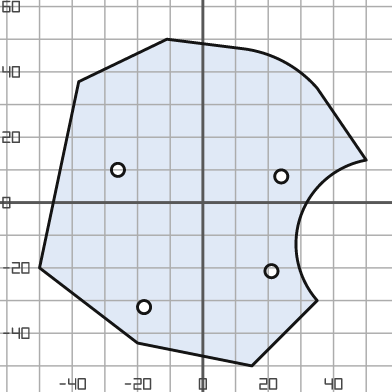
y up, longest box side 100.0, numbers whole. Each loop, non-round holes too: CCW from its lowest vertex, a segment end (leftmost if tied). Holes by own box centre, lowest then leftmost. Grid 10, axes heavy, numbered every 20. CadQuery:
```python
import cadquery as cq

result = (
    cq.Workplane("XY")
    .moveTo(15.0, -50.0)
    .lineTo(35.0, -30.0)
    .threePointArc((30.0, -4.0), (50.0, 13.0))
    .lineTo(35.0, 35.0)
    .threePointArc((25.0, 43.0), (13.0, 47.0))
    .lineTo(-11.0, 50.0)
    .lineTo(-38.0, 37.0)
    .lineTo(-50.0, -20.0)
    .lineTo(-20.0, -43.0)
    .close()
    .moveTo(-18.0, -32.0)
    .circle(2.0)
    .moveTo(21.0, -21.0)
    .circle(2.0)
    .moveTo(24.0, 8.0)
    .circle(2.0)
    .moveTo(-26.0, 10.0)
    .circle(2.0)
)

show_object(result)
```